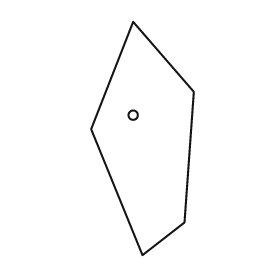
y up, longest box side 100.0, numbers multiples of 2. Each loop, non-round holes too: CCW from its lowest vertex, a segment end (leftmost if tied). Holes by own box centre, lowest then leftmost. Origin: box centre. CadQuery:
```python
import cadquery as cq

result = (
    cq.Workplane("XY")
    .moveTo(0.0, -50.0)
    .lineTo(18.0, -36.0)
    .lineTo(22.0, 20.0)
    .lineTo(-4.0, 50.0)
    .lineTo(-22.0, 4.0)
    .close()
    .moveTo(-4.0, 10.0)
    .circle(2.0)
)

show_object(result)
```